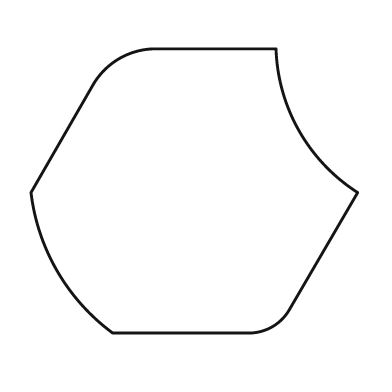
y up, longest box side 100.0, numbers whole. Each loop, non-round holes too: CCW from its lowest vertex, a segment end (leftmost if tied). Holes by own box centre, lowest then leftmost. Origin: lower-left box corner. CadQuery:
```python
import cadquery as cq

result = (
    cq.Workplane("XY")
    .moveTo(25.0, 0.0)
    .lineTo(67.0, 0.0)
    .threePointArc((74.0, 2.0), (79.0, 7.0))
    .lineTo(100.0, 43.0)
    .threePointArc((82.0, 62.0), (75.0, 87.0))
    .lineTo(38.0, 87.0)
    .threePointArc((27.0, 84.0), (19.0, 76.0))
    .lineTo(0.0, 43.0)
    .threePointArc((8.0, 19.0), (25.0, 0.0))
    .close()
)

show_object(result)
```